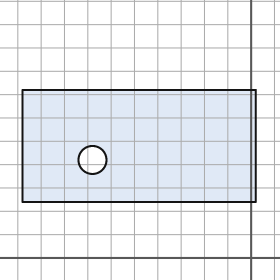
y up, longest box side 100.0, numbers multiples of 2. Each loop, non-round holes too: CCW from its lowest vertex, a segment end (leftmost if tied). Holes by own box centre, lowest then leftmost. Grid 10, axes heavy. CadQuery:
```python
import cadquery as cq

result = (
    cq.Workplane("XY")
    .moveTo(-98.0, 24.0)
    .lineTo(2.0, 24.0)
    .lineTo(2.0, 72.0)
    .lineTo(-98.0, 72.0)
    .close()
    .moveTo(-68.0, 42.0)
    .circle(6.0)
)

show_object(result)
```